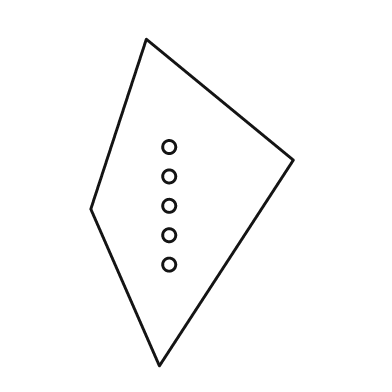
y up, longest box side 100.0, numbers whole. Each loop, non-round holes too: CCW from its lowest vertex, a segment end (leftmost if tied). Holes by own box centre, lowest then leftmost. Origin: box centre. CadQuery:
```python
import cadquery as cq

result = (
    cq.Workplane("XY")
    .moveTo(-10.0, -50.0)
    .lineTo(31.0, 13.0)
    .lineTo(-14.0, 50.0)
    .lineTo(-31.0, -2.0)
    .close()
    .moveTo(-7.0, -19.0)
    .circle(2.0)
    .moveTo(-7.0, -10.0)
    .circle(2.0)
    .moveTo(-7.0, -1.0)
    .circle(2.0)
    .moveTo(-7.0, 8.0)
    .circle(2.0)
    .moveTo(-7.0, 17.0)
    .circle(2.0)
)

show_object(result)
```